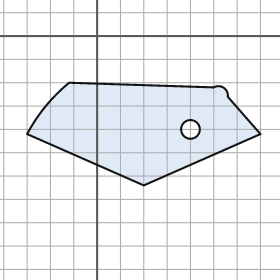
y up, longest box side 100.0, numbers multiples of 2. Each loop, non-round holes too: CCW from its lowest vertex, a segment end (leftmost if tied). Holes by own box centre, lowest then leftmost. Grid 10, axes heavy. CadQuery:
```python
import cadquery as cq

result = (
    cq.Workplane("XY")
    .moveTo(20.0, -64.0)
    .lineTo(70.0, -42.0)
    .lineTo(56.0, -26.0)
    .threePointArc((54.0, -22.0), (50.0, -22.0))
    .lineTo(-12.0, -20.0)
    .threePointArc((-22.0, -30.0), (-30.0, -42.0))
    .close()
    .moveTo(40.0, -40.0)
    .circle(4.0)
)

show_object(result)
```